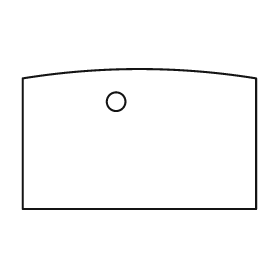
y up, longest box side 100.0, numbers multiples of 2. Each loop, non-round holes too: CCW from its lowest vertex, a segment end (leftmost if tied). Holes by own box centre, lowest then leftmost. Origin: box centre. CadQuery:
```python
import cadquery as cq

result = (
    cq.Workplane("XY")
    .moveTo(-50.0, -30.0)
    .lineTo(50.0, -30.0)
    .lineTo(50.0, 26.0)
    .threePointArc((0.0, 30.0), (-50.0, 26.0))
    .close()
    .moveTo(-10.0, 16.0)
    .circle(4.0)
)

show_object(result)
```